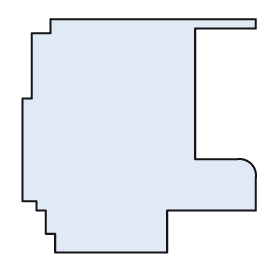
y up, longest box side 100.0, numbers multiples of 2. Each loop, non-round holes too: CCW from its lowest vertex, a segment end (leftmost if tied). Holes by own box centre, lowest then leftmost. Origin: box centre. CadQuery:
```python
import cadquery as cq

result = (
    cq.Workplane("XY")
    .moveTo(-36.0, -50.0)
    .lineTo(12.0, -50.0)
    .lineTo(12.0, -32.0)
    .lineTo(50.0, -32.0)
    .lineTo(50.0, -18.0)
    .threePointArc((48.0, -12.0), (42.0, -10.0))
    .lineTo(24.0, -10.0)
    .lineTo(24.0, 46.0)
    .lineTo(50.0, 46.0)
    .lineTo(50.0, 50.0)
    .lineTo(-38.0, 50.0)
    .lineTo(-38.0, 44.0)
    .lineTo(-46.0, 44.0)
    .lineTo(-46.0, 16.0)
    .lineTo(-50.0, 16.0)
    .lineTo(-50.0, -28.0)
    .lineTo(-44.0, -28.0)
    .lineTo(-44.0, -32.0)
    .lineTo(-40.0, -32.0)
    .lineTo(-40.0, -42.0)
    .lineTo(-36.0, -42.0)
    .close()
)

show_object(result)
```